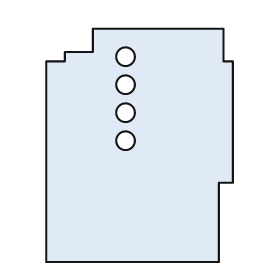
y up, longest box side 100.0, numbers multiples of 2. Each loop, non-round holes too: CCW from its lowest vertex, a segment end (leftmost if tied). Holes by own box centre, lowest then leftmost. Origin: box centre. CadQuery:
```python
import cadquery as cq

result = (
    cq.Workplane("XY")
    .moveTo(-40.0, -50.0)
    .lineTo(34.0, -50.0)
    .lineTo(34.0, -16.0)
    .lineTo(40.0, -16.0)
    .lineTo(40.0, 36.0)
    .lineTo(36.0, 36.0)
    .lineTo(36.0, 50.0)
    .lineTo(-20.0, 50.0)
    .lineTo(-20.0, 40.0)
    .lineTo(-32.0, 40.0)
    .lineTo(-32.0, 36.0)
    .lineTo(-40.0, 36.0)
    .close()
    .moveTo(-6.0, 2.0)
    .circle(4.0)
    .moveTo(-6.0, 14.0)
    .circle(4.0)
    .moveTo(-6.0, 26.0)
    .circle(4.0)
    .moveTo(-6.0, 38.0)
    .circle(4.0)
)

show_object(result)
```